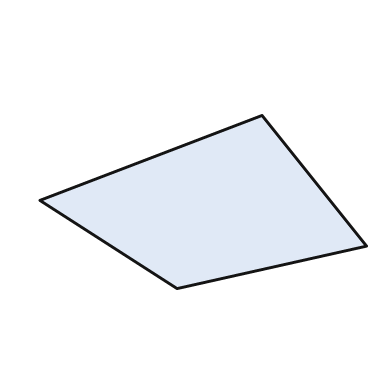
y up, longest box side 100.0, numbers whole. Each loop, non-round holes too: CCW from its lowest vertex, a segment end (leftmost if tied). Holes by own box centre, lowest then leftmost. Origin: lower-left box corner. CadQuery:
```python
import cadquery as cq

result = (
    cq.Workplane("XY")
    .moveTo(42.0, 0.0)
    .lineTo(100.0, 13.0)
    .lineTo(68.0, 53.0)
    .lineTo(0.0, 27.0)
    .close()
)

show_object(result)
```